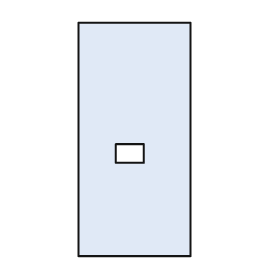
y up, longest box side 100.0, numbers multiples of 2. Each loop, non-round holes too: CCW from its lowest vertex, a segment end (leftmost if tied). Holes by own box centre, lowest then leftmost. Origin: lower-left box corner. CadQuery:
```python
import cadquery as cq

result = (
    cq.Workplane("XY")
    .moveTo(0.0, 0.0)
    .lineTo(48.0, 0.0)
    .lineTo(48.0, 100.0)
    .lineTo(0.0, 100.0)
    .close()
    .moveTo(16.0, 40.0)
    .lineTo(28.0, 40.0)
    .lineTo(28.0, 48.0)
    .lineTo(16.0, 48.0)
    .close()
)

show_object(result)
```